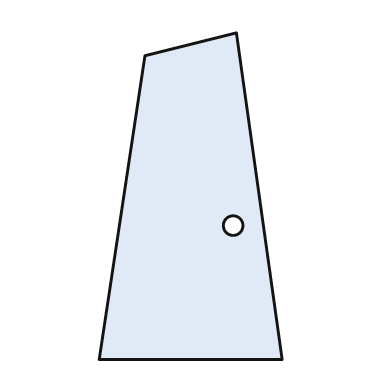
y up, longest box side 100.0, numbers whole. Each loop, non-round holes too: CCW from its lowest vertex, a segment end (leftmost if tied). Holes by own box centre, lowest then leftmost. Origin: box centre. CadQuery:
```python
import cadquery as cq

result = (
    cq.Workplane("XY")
    .moveTo(-28.0, -50.0)
    .lineTo(28.0, -50.0)
    .lineTo(14.0, 50.0)
    .lineTo(-14.0, 43.0)
    .close()
    .moveTo(13.0, -9.0)
    .circle(3.0)
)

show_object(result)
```